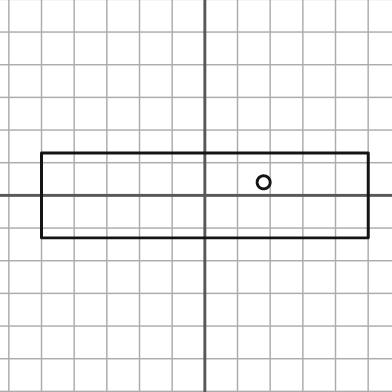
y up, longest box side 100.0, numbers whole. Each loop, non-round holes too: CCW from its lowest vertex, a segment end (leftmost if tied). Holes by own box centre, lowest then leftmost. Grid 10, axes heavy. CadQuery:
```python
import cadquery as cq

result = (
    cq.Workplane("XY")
    .moveTo(-50.0, -13.0)
    .lineTo(50.0, -13.0)
    .lineTo(50.0, 13.0)
    .lineTo(-50.0, 13.0)
    .close()
    .moveTo(18.0, 4.0)
    .circle(2.0)
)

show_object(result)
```